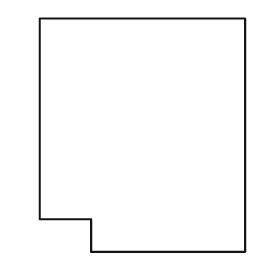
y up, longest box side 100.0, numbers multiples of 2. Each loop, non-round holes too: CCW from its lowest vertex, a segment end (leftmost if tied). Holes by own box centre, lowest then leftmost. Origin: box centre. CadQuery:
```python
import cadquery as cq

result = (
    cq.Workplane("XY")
    .moveTo(-22.0, -50.0)
    .lineTo(44.0, -50.0)
    .lineTo(44.0, 50.0)
    .lineTo(-44.0, 50.0)
    .lineTo(-44.0, -36.0)
    .lineTo(-22.0, -36.0)
    .close()
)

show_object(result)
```